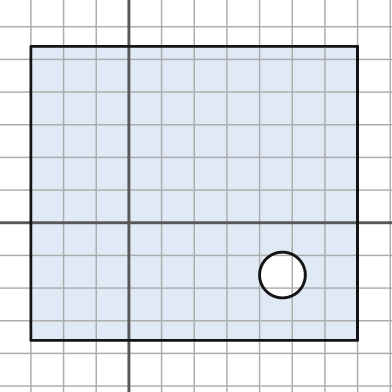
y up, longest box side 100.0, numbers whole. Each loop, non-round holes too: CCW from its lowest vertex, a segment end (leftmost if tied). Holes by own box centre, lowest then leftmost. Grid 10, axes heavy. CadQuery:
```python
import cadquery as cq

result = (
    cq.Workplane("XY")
    .moveTo(-30.0, -36.0)
    .lineTo(70.0, -36.0)
    .lineTo(70.0, 54.0)
    .lineTo(-30.0, 54.0)
    .close()
    .moveTo(47.0, -16.0)
    .circle(7.0)
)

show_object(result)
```